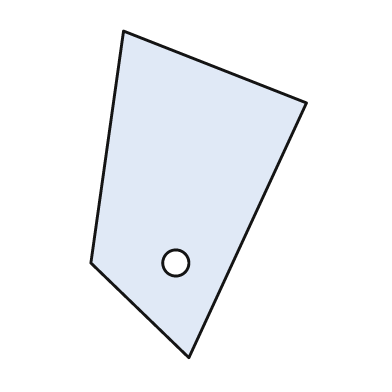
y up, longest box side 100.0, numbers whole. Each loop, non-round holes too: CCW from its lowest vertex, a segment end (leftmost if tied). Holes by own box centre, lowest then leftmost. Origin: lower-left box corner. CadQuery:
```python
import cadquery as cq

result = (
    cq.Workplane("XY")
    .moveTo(30.0, 0.0)
    .lineTo(66.0, 78.0)
    .lineTo(10.0, 100.0)
    .lineTo(0.0, 29.0)
    .close()
    .moveTo(26.0, 29.0)
    .circle(4.0)
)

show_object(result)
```